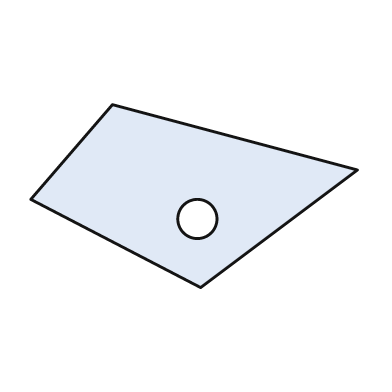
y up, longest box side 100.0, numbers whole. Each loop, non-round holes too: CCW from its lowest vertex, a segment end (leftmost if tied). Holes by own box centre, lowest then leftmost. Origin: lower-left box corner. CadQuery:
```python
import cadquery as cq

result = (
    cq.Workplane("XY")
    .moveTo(52.0, 0.0)
    .lineTo(100.0, 36.0)
    .lineTo(25.0, 56.0)
    .lineTo(0.0, 27.0)
    .close()
    .moveTo(51.0, 21.0)
    .circle(6.0)
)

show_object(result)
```